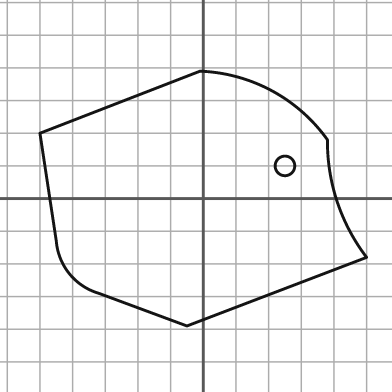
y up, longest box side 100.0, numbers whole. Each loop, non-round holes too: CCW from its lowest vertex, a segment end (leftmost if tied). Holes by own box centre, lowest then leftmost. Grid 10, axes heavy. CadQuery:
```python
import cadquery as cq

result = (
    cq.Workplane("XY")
    .moveTo(-5.0, -39.0)
    .lineTo(50.0, -18.0)
    .threePointArc((41.0, -1.0), (38.0, 18.0))
    .threePointArc((21.0, 33.0), (-1.0, 39.0))
    .lineTo(-50.0, 20.0)
    .lineTo(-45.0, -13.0)
    .threePointArc((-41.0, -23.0), (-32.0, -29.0))
    .close()
    .moveTo(25.0, 10.0)
    .circle(3.0)
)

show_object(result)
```